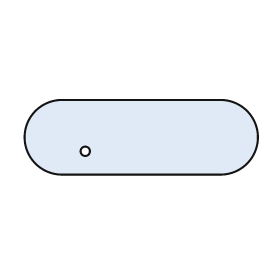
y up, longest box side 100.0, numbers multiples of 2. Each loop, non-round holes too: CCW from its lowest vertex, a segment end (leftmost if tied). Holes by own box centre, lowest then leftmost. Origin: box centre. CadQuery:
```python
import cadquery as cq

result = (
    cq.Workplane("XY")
    .moveTo(-34.0, -16.0)
    .lineTo(34.0, -16.0)
    .threePointArc((50.0, 0.0), (34.0, 16.0))
    .lineTo(-34.0, 16.0)
    .threePointArc((-50.0, 0.0), (-34.0, -16.0))
    .close()
    .moveTo(-24.0, -6.0)
    .circle(2.0)
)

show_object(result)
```